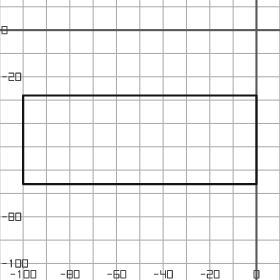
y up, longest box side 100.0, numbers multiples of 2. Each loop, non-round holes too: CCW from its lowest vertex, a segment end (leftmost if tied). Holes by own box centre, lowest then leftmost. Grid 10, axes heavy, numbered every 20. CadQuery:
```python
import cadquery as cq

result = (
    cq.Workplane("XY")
    .moveTo(-100.0, -66.0)
    .lineTo(0.0, -66.0)
    .lineTo(0.0, -28.0)
    .lineTo(-100.0, -28.0)
    .close()
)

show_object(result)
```